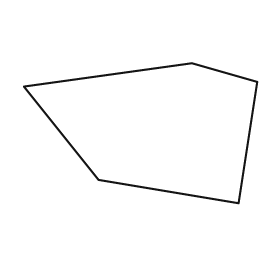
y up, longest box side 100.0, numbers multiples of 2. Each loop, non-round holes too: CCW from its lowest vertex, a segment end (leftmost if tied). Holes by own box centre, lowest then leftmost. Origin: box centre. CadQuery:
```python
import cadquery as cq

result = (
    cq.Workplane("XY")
    .moveTo(42.0, -30.0)
    .lineTo(50.0, 22.0)
    .lineTo(22.0, 30.0)
    .lineTo(-50.0, 20.0)
    .lineTo(-18.0, -20.0)
    .close()
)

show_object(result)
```